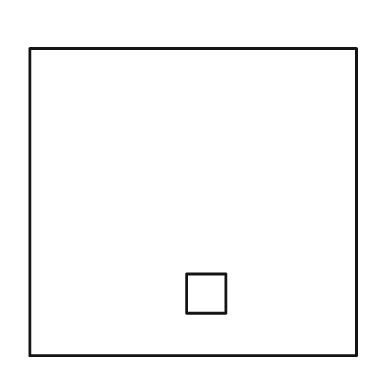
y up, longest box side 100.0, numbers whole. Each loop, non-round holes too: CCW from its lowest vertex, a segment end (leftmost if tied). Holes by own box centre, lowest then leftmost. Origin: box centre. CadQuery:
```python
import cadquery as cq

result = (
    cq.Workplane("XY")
    .moveTo(-50.0, -47.0)
    .lineTo(50.0, -47.0)
    .lineTo(50.0, 47.0)
    .lineTo(-50.0, 47.0)
    .close()
    .moveTo(-2.0, -34.0)
    .lineTo(10.0, -34.0)
    .lineTo(10.0, -22.0)
    .lineTo(-2.0, -22.0)
    .close()
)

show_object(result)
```